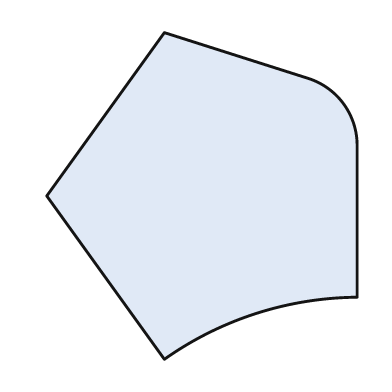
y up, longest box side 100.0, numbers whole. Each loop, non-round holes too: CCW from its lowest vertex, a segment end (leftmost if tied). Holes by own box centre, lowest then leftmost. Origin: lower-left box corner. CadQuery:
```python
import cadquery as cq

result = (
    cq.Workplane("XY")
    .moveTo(36.0, 0.0)
    .threePointArc((64.0, 14.0), (95.0, 19.0))
    .lineTo(95.0, 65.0)
    .threePointArc((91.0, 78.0), (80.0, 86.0))
    .lineTo(36.0, 100.0)
    .lineTo(0.0, 50.0)
    .close()
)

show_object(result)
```